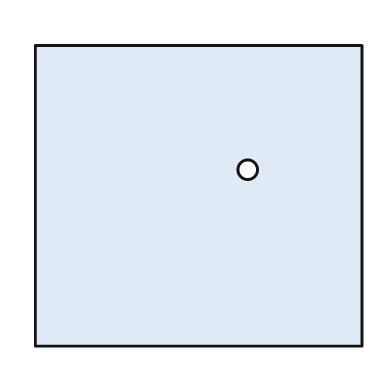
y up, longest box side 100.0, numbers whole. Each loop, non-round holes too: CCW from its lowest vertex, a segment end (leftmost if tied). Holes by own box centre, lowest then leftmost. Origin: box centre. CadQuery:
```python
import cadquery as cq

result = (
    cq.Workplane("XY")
    .moveTo(-50.0, -46.0)
    .lineTo(50.0, -46.0)
    .lineTo(50.0, 46.0)
    .lineTo(-50.0, 46.0)
    .close()
    .moveTo(15.0, 8.0)
    .circle(3.0)
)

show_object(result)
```